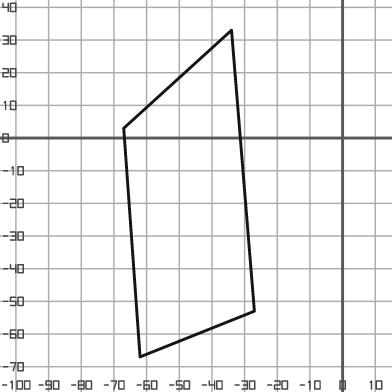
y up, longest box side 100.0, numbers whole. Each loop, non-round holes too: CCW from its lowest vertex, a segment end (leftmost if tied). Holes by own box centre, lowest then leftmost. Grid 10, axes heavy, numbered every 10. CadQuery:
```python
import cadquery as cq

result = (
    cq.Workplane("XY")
    .moveTo(-62.0, -67.0)
    .lineTo(-27.0, -53.0)
    .lineTo(-34.0, 33.0)
    .lineTo(-67.0, 3.0)
    .close()
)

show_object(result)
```